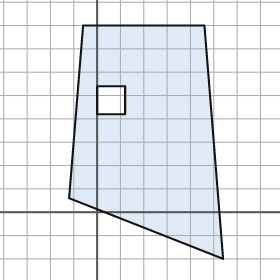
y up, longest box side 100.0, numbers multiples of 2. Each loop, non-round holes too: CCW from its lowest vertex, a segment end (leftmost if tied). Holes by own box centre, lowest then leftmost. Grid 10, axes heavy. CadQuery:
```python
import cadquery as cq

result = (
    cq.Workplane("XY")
    .moveTo(54.0, -20.0)
    .lineTo(46.0, 80.0)
    .lineTo(-6.0, 80.0)
    .lineTo(-12.0, 6.0)
    .close()
    .moveTo(0.0, 42.0)
    .lineTo(12.0, 42.0)
    .lineTo(12.0, 54.0)
    .lineTo(0.0, 54.0)
    .close()
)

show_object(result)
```